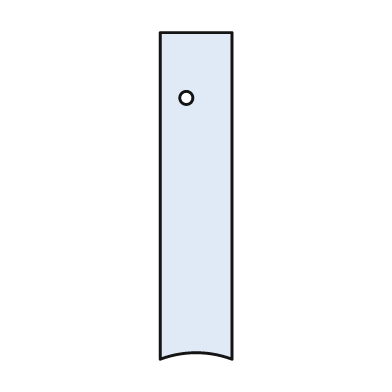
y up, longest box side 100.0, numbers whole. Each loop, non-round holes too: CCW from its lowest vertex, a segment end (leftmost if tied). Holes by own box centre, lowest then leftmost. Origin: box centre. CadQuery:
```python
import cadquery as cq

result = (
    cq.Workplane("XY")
    .moveTo(-11.0, -50.0)
    .threePointArc((0.0, -48.0), (11.0, -50.0))
    .lineTo(11.0, 50.0)
    .lineTo(-11.0, 50.0)
    .close()
    .moveTo(-3.0, 30.0)
    .circle(2.0)
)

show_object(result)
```